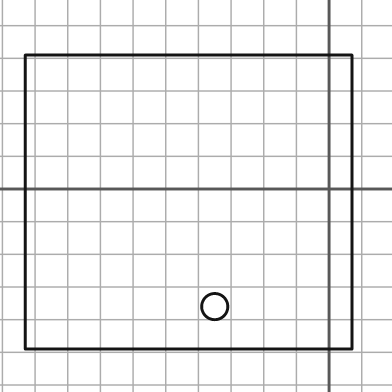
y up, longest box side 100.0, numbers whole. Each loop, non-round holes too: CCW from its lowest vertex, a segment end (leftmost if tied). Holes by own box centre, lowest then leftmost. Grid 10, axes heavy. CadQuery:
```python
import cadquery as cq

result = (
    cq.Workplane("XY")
    .moveTo(-93.0, -49.0)
    .lineTo(7.0, -49.0)
    .lineTo(7.0, 41.0)
    .lineTo(-93.0, 41.0)
    .close()
    .moveTo(-35.0, -36.0)
    .circle(4.0)
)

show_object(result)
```